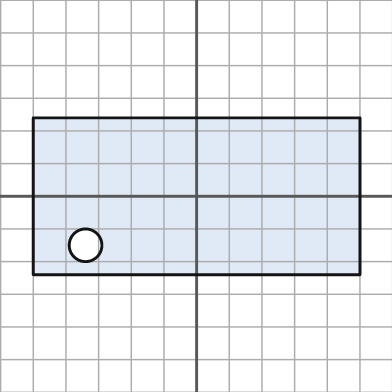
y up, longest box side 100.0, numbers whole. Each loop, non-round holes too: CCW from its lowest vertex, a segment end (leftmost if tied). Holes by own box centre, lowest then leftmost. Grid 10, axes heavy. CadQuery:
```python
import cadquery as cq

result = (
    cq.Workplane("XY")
    .moveTo(-50.0, -24.0)
    .lineTo(50.0, -24.0)
    .lineTo(50.0, 24.0)
    .lineTo(-50.0, 24.0)
    .close()
    .moveTo(-34.0, -15.0)
    .circle(5.0)
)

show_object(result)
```